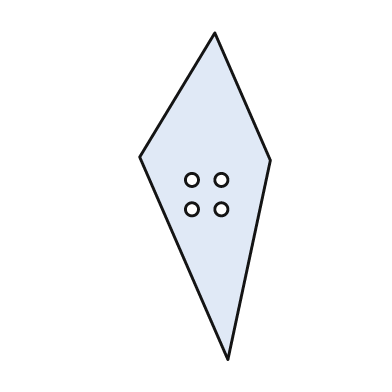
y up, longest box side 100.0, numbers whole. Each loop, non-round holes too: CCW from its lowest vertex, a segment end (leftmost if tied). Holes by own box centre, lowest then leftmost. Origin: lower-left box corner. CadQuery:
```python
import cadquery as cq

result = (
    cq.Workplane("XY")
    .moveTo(27.0, 0.0)
    .lineTo(40.0, 61.0)
    .lineTo(23.0, 100.0)
    .lineTo(0.0, 62.0)
    .close()
    .moveTo(16.0, 46.0)
    .circle(2.0)
    .moveTo(25.0, 46.0)
    .circle(2.0)
    .moveTo(16.0, 55.0)
    .circle(2.0)
    .moveTo(25.0, 55.0)
    .circle(2.0)
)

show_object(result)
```